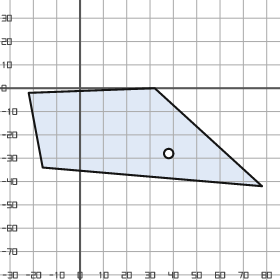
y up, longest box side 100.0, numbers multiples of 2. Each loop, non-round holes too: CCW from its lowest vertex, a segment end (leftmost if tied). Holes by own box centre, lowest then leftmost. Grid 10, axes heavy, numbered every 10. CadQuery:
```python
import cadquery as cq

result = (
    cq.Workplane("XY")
    .moveTo(78.0, -42.0)
    .lineTo(32.0, 0.0)
    .lineTo(-22.0, -2.0)
    .lineTo(-16.0, -34.0)
    .close()
    .moveTo(38.0, -28.0)
    .circle(2.0)
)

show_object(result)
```